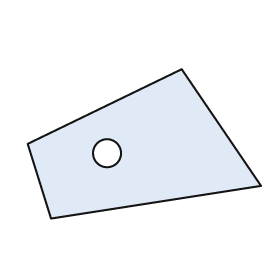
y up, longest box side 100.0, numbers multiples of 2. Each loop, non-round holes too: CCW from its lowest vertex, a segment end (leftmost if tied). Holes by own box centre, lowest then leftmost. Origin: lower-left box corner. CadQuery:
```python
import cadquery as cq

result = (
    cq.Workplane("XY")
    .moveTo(10.0, 0.0)
    .lineTo(100.0, 14.0)
    .lineTo(66.0, 64.0)
    .lineTo(0.0, 32.0)
    .close()
    .moveTo(34.0, 28.0)
    .circle(6.0)
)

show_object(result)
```